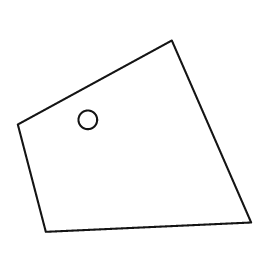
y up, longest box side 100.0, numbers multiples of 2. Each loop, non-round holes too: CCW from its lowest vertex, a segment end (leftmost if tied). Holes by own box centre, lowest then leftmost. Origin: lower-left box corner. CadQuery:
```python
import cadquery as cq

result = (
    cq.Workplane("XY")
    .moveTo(12.0, 0.0)
    .lineTo(100.0, 4.0)
    .lineTo(66.0, 82.0)
    .lineTo(0.0, 46.0)
    .close()
    .moveTo(30.0, 48.0)
    .circle(4.0)
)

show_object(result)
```